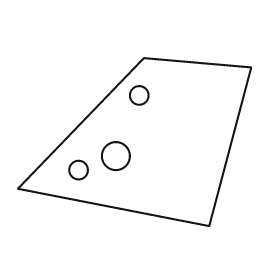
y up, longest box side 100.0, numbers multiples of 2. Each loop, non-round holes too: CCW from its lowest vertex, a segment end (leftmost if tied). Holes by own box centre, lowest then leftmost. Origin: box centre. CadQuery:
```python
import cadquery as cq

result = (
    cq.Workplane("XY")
    .moveTo(32.0, -36.0)
    .lineTo(50.0, 32.0)
    .lineTo(4.0, 36.0)
    .lineTo(-50.0, -20.0)
    .close()
    .moveTo(-24.0, -12.0)
    .circle(4.0)
    .moveTo(-8.0, -6.0)
    .circle(6.0)
    .moveTo(2.0, 20.0)
    .circle(4.0)
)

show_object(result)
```